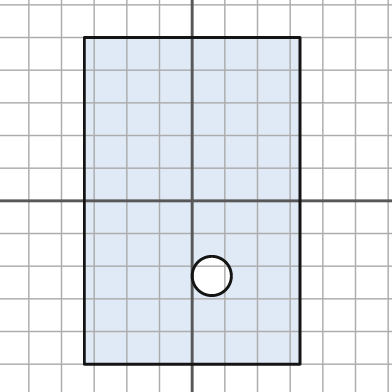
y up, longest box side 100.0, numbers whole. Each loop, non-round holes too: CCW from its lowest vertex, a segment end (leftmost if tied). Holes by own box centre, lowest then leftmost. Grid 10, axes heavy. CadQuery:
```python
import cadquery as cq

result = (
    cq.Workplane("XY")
    .moveTo(-33.0, -50.0)
    .lineTo(33.0, -50.0)
    .lineTo(33.0, 50.0)
    .lineTo(-33.0, 50.0)
    .close()
    .moveTo(6.0, -23.0)
    .circle(6.0)
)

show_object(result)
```